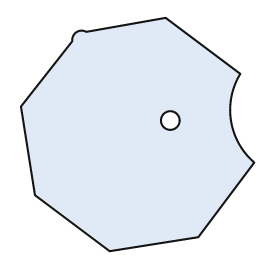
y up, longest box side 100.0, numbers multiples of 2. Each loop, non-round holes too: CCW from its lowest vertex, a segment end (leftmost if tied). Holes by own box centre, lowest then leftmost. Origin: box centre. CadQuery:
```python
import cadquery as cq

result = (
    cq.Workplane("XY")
    .moveTo(-12.0, -50.0)
    .lineTo(26.0, -44.0)
    .lineTo(50.0, -12.0)
    .threePointArc((40.0, 6.0), (44.0, 26.0))
    .lineTo(12.0, 50.0)
    .lineTo(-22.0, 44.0)
    .threePointArc((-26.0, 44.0), (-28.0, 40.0))
    .lineTo(-50.0, 12.0)
    .lineTo(-44.0, -26.0)
    .close()
    .moveTo(14.0, 6.0)
    .circle(4.0)
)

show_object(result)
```